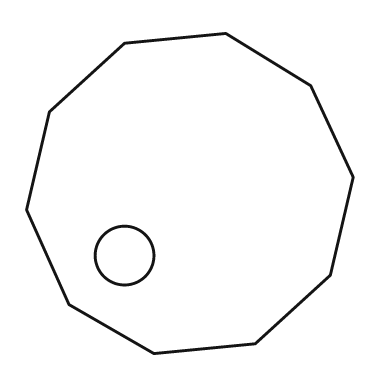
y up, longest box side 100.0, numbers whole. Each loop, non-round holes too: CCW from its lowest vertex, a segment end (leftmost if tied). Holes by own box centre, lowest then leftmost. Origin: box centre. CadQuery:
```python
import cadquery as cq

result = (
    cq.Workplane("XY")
    .moveTo(-11.0, -49.0)
    .lineTo(20.0, -46.0)
    .lineTo(43.0, -25.0)
    .lineTo(50.0, 5.0)
    .lineTo(37.0, 33.0)
    .lineTo(11.0, 49.0)
    .lineTo(-20.0, 46.0)
    .lineTo(-43.0, 25.0)
    .lineTo(-50.0, -5.0)
    .lineTo(-37.0, -34.0)
    .close()
    .moveTo(-20.0, -19.0)
    .circle(9.0)
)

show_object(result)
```